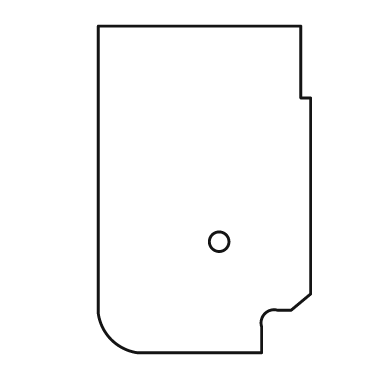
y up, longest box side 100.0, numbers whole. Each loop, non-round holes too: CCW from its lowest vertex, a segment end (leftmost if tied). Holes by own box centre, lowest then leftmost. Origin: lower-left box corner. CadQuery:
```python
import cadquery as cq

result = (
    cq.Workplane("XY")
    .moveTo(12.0, 0.0)
    .lineTo(50.0, 0.0)
    .lineTo(50.0, 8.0)
    .threePointArc((51.0, 12.0), (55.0, 13.0))
    .lineTo(59.0, 13.0)
    .lineTo(65.0, 18.0)
    .lineTo(65.0, 78.0)
    .lineTo(62.0, 78.0)
    .lineTo(62.0, 100.0)
    .lineTo(0.0, 100.0)
    .lineTo(0.0, 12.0)
    .threePointArc((4.0, 4.0), (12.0, 0.0))
    .close()
    .moveTo(37.0, 34.0)
    .circle(3.0)
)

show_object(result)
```